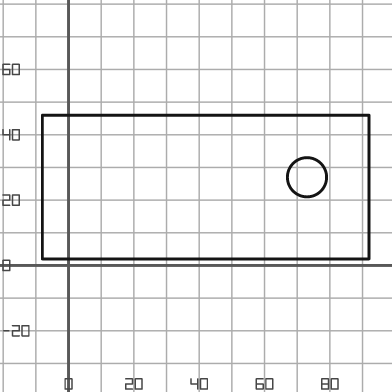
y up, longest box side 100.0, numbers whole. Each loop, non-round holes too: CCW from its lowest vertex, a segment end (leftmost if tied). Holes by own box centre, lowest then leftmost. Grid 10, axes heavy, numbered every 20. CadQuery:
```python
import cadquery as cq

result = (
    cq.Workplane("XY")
    .moveTo(-8.0, 2.0)
    .lineTo(92.0, 2.0)
    .lineTo(92.0, 46.0)
    .lineTo(-8.0, 46.0)
    .close()
    .moveTo(73.0, 27.0)
    .circle(6.0)
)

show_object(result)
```